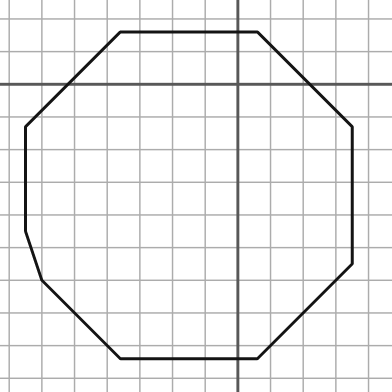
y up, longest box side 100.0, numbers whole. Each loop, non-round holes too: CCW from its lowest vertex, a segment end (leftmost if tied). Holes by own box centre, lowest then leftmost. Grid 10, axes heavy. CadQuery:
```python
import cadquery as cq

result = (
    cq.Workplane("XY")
    .moveTo(-36.0, -84.0)
    .lineTo(6.0, -84.0)
    .lineTo(35.0, -55.0)
    .lineTo(35.0, -13.0)
    .lineTo(6.0, 16.0)
    .lineTo(-36.0, 16.0)
    .lineTo(-65.0, -13.0)
    .lineTo(-65.0, -45.0)
    .lineTo(-60.0, -60.0)
    .close()
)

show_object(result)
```